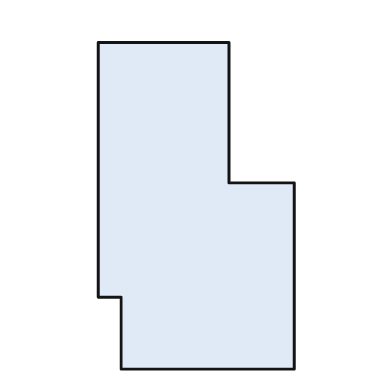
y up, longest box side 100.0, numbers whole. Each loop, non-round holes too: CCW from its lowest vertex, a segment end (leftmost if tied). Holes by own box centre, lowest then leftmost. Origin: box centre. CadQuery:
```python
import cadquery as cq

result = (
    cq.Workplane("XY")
    .moveTo(-23.0, -50.0)
    .lineTo(30.0, -50.0)
    .lineTo(30.0, 7.0)
    .lineTo(10.0, 7.0)
    .lineTo(10.0, 50.0)
    .lineTo(-30.0, 50.0)
    .lineTo(-30.0, -28.0)
    .lineTo(-23.0, -28.0)
    .close()
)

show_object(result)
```